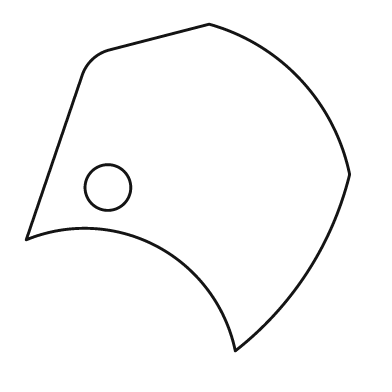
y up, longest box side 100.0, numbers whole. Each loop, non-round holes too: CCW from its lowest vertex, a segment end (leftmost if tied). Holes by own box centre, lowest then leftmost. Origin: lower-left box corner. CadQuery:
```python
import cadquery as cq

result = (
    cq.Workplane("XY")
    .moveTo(64.0, 0.0)
    .threePointArc((86.0, 24.0), (99.0, 54.0))
    .threePointArc((84.0, 83.0), (56.0, 100.0))
    .lineTo(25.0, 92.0)
    .threePointArc((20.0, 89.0), (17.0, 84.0))
    .lineTo(0.0, 34.0)
    .threePointArc((40.0, 32.0), (64.0, 0.0))
    .close()
    .moveTo(25.0, 50.0)
    .circle(7.0)
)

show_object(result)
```